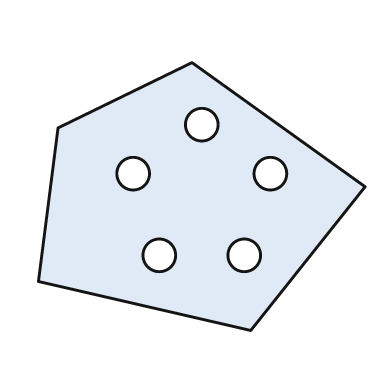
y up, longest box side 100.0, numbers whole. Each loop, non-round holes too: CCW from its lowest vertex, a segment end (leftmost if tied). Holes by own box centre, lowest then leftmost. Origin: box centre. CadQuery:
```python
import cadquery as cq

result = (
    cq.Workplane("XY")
    .moveTo(15.0, -41.0)
    .lineTo(50.0, 3.0)
    .lineTo(-3.0, 41.0)
    .lineTo(-44.0, 21.0)
    .lineTo(-50.0, -26.0)
    .close()
    .moveTo(-13.0, -18.0)
    .circle(5.0)
    .moveTo(13.0, -18.0)
    .circle(5.0)
    .moveTo(-21.0, 7.0)
    .circle(5.0)
    .moveTo(21.0, 7.0)
    .circle(5.0)
    .moveTo(0.0, 22.0)
    .circle(5.0)
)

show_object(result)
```